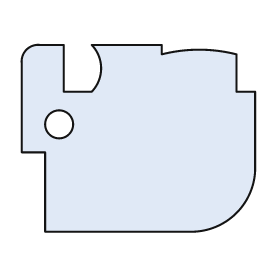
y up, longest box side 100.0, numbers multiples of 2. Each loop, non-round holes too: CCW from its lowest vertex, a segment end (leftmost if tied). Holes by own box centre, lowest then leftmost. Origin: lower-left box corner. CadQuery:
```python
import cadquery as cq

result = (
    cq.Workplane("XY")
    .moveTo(10.0, 0.0)
    .lineTo(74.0, 0.0)
    .threePointArc((92.0, 8.0), (100.0, 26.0))
    .lineTo(100.0, 60.0)
    .lineTo(92.0, 60.0)
    .lineTo(92.0, 76.0)
    .threePointArc((76.0, 78.0), (60.0, 76.0))
    .lineTo(60.0, 80.0)
    .lineTo(30.0, 80.0)
    .threePointArc((34.0, 70.0), (30.0, 60.0))
    .lineTo(18.0, 60.0)
    .lineTo(18.0, 80.0)
    .lineTo(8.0, 80.0)
    .threePointArc((2.0, 78.0), (0.0, 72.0))
    .lineTo(0.0, 34.0)
    .lineTo(10.0, 34.0)
    .close()
    .moveTo(16.0, 46.0)
    .circle(6.0)
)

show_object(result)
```